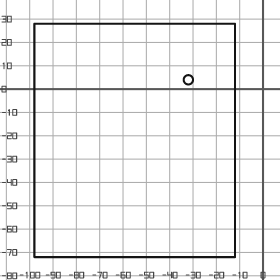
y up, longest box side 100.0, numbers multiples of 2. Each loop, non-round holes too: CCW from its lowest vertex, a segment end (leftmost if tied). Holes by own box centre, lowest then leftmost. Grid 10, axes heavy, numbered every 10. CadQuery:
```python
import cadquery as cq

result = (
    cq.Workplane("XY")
    .moveTo(-98.0, -72.0)
    .lineTo(-12.0, -72.0)
    .lineTo(-12.0, 28.0)
    .lineTo(-98.0, 28.0)
    .close()
    .moveTo(-32.0, 4.0)
    .circle(2.0)
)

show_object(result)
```